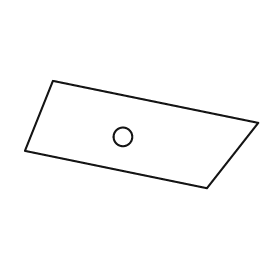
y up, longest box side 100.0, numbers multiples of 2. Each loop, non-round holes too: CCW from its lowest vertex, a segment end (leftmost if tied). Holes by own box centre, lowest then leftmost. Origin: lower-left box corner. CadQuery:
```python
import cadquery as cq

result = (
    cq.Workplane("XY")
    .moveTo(78.0, 0.0)
    .lineTo(100.0, 28.0)
    .lineTo(12.0, 46.0)
    .lineTo(0.0, 16.0)
    .close()
    .moveTo(42.0, 22.0)
    .circle(4.0)
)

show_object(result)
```